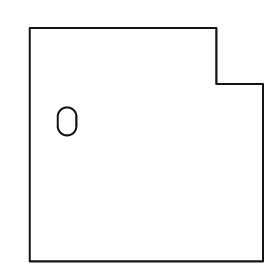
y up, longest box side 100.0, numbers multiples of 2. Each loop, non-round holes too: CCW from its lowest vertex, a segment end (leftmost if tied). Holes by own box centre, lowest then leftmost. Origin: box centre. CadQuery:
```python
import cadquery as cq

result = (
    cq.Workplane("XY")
    .moveTo(-50.0, -50.0)
    .lineTo(50.0, -50.0)
    .lineTo(50.0, 26.0)
    .lineTo(30.0, 26.0)
    .lineTo(30.0, 50.0)
    .lineTo(-50.0, 50.0)
    .close()
    .moveTo(-38.0, 8.0)
    .threePointArc((-34.0, 4.0), (-30.0, 8.0))
    .lineTo(-30.0, 12.0)
    .threePointArc((-34.0, 16.0), (-38.0, 12.0))
    .close()
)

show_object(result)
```